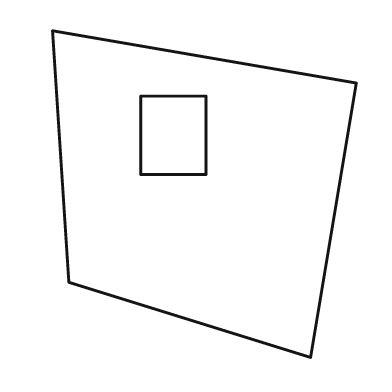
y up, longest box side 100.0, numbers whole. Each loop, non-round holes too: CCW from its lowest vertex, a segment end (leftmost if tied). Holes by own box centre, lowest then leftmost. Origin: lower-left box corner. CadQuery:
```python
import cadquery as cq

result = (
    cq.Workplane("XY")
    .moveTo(79.0, 0.0)
    .lineTo(93.0, 84.0)
    .lineTo(0.0, 100.0)
    .lineTo(5.0, 23.0)
    .close()
    .moveTo(27.0, 56.0)
    .lineTo(47.0, 56.0)
    .lineTo(47.0, 80.0)
    .lineTo(27.0, 80.0)
    .close()
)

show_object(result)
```